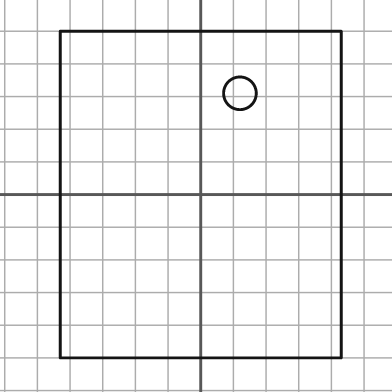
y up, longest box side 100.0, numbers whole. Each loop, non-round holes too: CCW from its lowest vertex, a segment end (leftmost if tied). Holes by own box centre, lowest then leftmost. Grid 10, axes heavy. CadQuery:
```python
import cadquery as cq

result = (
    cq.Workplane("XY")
    .moveTo(-43.0, -50.0)
    .lineTo(43.0, -50.0)
    .lineTo(43.0, 50.0)
    .lineTo(-43.0, 50.0)
    .close()
    .moveTo(12.0, 31.0)
    .circle(5.0)
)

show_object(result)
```